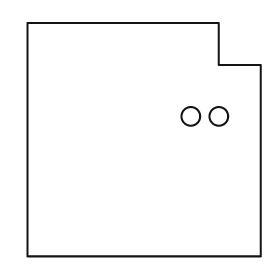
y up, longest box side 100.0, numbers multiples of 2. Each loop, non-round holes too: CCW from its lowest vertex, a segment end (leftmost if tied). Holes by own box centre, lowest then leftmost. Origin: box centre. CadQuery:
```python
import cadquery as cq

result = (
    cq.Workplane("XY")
    .moveTo(-50.0, -50.0)
    .lineTo(50.0, -50.0)
    .lineTo(50.0, 32.0)
    .lineTo(32.0, 32.0)
    .lineTo(32.0, 50.0)
    .lineTo(-50.0, 50.0)
    .close()
    .moveTo(20.0, 10.0)
    .circle(4.0)
    .moveTo(32.0, 10.0)
    .circle(4.0)
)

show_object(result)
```